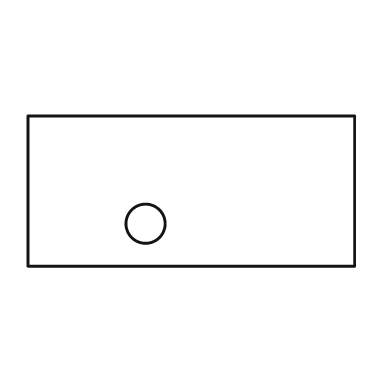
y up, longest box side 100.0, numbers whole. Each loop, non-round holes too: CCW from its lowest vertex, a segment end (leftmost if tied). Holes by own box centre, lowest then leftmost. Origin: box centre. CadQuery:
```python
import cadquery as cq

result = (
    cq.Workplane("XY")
    .moveTo(-50.0, -23.0)
    .lineTo(50.0, -23.0)
    .lineTo(50.0, 23.0)
    .lineTo(-50.0, 23.0)
    .close()
    .moveTo(-14.0, -10.0)
    .circle(6.0)
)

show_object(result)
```